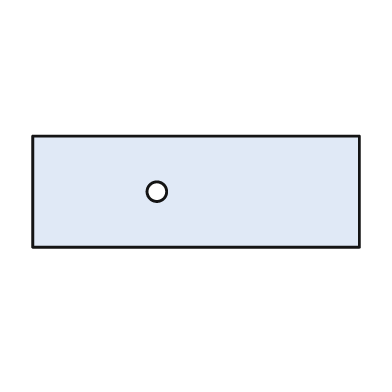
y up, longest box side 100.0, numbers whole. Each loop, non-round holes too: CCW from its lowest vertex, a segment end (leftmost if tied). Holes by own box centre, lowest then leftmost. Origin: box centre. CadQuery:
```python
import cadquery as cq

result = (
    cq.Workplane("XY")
    .moveTo(-50.0, -17.0)
    .lineTo(50.0, -17.0)
    .lineTo(50.0, 17.0)
    .lineTo(-50.0, 17.0)
    .close()
    .moveTo(-12.0, 0.0)
    .circle(3.0)
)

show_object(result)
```